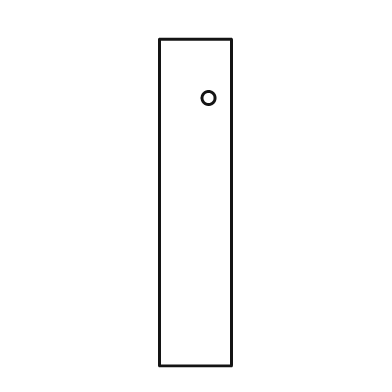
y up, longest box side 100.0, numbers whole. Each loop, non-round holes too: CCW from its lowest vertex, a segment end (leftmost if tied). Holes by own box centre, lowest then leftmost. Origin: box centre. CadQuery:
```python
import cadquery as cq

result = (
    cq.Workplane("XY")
    .moveTo(-11.0, -50.0)
    .lineTo(11.0, -50.0)
    .lineTo(11.0, 50.0)
    .lineTo(-11.0, 50.0)
    .close()
    .moveTo(4.0, 32.0)
    .circle(2.0)
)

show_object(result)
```